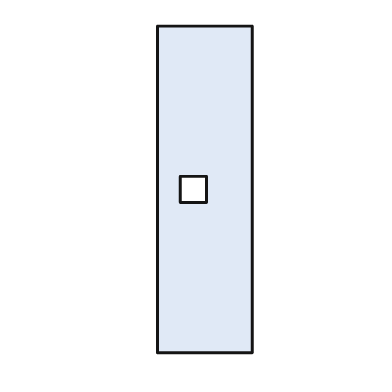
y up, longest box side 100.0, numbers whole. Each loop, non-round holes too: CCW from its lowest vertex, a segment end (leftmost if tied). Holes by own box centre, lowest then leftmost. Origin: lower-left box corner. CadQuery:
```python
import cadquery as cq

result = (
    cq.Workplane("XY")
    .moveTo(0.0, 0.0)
    .lineTo(29.0, 0.0)
    .lineTo(29.0, 100.0)
    .lineTo(0.0, 100.0)
    .close()
    .moveTo(7.0, 46.0)
    .lineTo(15.0, 46.0)
    .lineTo(15.0, 54.0)
    .lineTo(7.0, 54.0)
    .close()
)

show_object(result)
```